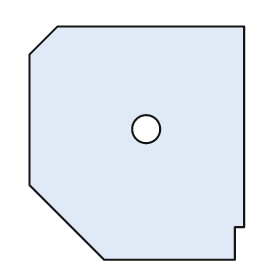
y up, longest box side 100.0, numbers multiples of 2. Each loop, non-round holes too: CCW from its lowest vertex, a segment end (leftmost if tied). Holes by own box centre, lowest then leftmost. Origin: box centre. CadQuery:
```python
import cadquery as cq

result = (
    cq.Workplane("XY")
    .moveTo(-14.0, -50.0)
    .lineTo(42.0, -50.0)
    .lineTo(42.0, -36.0)
    .lineTo(46.0, -36.0)
    .lineTo(46.0, 50.0)
    .lineTo(-34.0, 50.0)
    .lineTo(-46.0, 38.0)
    .lineTo(-46.0, -18.0)
    .close()
    .moveTo(4.0, 6.0)
    .circle(6.0)
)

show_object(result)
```